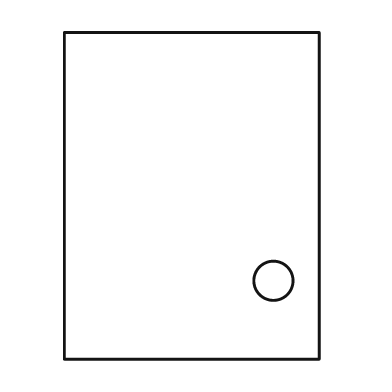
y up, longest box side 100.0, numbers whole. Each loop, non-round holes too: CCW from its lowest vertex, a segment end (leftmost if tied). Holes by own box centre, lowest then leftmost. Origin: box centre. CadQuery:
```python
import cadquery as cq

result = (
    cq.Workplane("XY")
    .moveTo(-39.0, -50.0)
    .lineTo(39.0, -50.0)
    .lineTo(39.0, 50.0)
    .lineTo(-39.0, 50.0)
    .close()
    .moveTo(25.0, -26.0)
    .circle(6.0)
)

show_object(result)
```